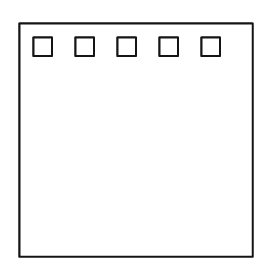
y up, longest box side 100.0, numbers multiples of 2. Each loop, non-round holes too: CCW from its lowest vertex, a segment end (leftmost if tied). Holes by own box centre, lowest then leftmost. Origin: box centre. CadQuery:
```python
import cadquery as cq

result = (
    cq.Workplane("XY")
    .moveTo(-50.0, -50.0)
    .lineTo(50.0, -50.0)
    .lineTo(50.0, 50.0)
    .lineTo(-50.0, 50.0)
    .close()
    .moveTo(-44.0, 36.0)
    .lineTo(-36.0, 36.0)
    .lineTo(-36.0, 44.0)
    .lineTo(-44.0, 44.0)
    .close()
    .moveTo(-26.0, 36.0)
    .lineTo(-18.0, 36.0)
    .lineTo(-18.0, 44.0)
    .lineTo(-26.0, 44.0)
    .close()
    .moveTo(-8.0, 36.0)
    .lineTo(0.0, 36.0)
    .lineTo(0.0, 44.0)
    .lineTo(-8.0, 44.0)
    .close()
    .moveTo(10.0, 36.0)
    .lineTo(18.0, 36.0)
    .lineTo(18.0, 44.0)
    .lineTo(10.0, 44.0)
    .close()
    .moveTo(28.0, 36.0)
    .lineTo(36.0, 36.0)
    .lineTo(36.0, 44.0)
    .lineTo(28.0, 44.0)
    .close()
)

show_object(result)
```